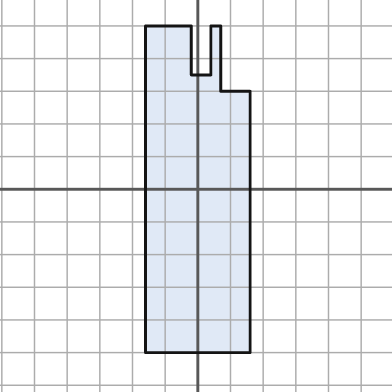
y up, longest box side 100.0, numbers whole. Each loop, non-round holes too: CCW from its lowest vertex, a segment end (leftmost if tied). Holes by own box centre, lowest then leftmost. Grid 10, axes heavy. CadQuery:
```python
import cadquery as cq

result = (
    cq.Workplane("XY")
    .moveTo(-16.0, -50.0)
    .lineTo(16.0, -50.0)
    .lineTo(16.0, 30.0)
    .lineTo(7.0, 30.0)
    .lineTo(7.0, 50.0)
    .lineTo(4.0, 50.0)
    .lineTo(4.0, 35.0)
    .lineTo(-2.0, 35.0)
    .lineTo(-2.0, 50.0)
    .lineTo(-16.0, 50.0)
    .close()
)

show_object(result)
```